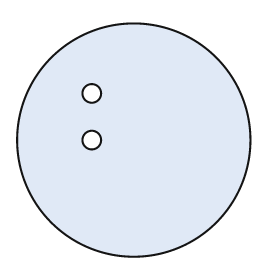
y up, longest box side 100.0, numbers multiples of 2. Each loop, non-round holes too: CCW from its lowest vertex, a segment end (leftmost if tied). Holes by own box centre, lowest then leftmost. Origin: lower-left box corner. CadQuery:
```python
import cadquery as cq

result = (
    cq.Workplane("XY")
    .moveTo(50.0, 50.0)
    .circle(50.0)
    .moveTo(32.0, 50.0)
    .circle(4.0)
    .moveTo(32.0, 70.0)
    .circle(4.0)
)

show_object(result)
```